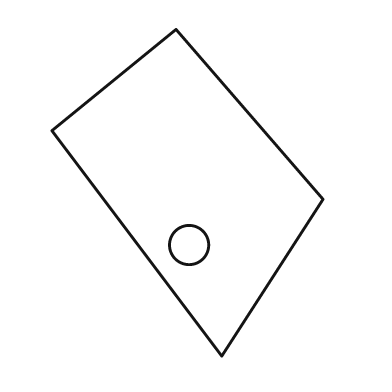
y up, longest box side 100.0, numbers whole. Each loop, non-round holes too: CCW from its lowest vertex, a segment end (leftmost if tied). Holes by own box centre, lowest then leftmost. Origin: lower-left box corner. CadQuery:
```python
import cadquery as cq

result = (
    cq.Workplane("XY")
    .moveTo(52.0, 0.0)
    .lineTo(83.0, 48.0)
    .lineTo(38.0, 100.0)
    .lineTo(0.0, 69.0)
    .close()
    .moveTo(42.0, 34.0)
    .circle(6.0)
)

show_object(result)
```